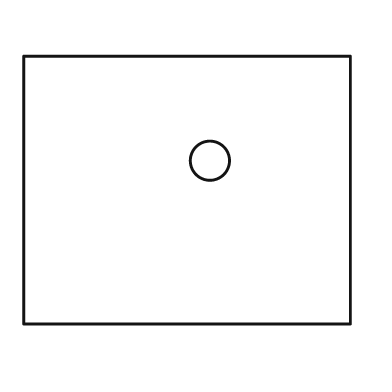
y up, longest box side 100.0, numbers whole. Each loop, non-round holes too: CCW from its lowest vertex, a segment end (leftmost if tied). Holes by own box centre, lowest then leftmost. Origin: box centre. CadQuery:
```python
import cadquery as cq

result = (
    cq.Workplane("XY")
    .moveTo(-50.0, -41.0)
    .lineTo(50.0, -41.0)
    .lineTo(50.0, 41.0)
    .lineTo(-50.0, 41.0)
    .close()
    .moveTo(7.0, 9.0)
    .circle(6.0)
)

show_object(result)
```